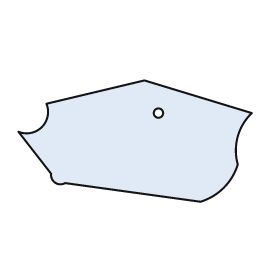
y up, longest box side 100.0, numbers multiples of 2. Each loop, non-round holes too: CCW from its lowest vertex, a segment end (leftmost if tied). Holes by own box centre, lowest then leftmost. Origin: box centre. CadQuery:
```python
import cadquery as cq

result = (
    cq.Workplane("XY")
    .moveTo(28.0, -26.0)
    .threePointArc((38.0, -20.0), (44.0, -10.0))
    .threePointArc((44.0, 2.0), (50.0, 12.0))
    .lineTo(4.0, 26.0)
    .lineTo(-38.0, 16.0)
    .threePointArc((-40.0, 6.0), (-50.0, 4.0))
    .lineTo(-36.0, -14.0)
    .threePointArc((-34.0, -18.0), (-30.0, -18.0))
    .close()
    .moveTo(10.0, 12.0)
    .circle(2.0)
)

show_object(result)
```